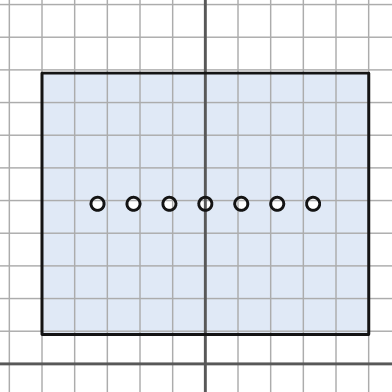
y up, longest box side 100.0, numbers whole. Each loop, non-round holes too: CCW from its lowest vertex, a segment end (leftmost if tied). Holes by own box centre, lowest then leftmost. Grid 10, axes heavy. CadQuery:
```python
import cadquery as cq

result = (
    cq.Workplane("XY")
    .moveTo(-50.0, 9.0)
    .lineTo(50.0, 9.0)
    .lineTo(50.0, 89.0)
    .lineTo(-50.0, 89.0)
    .close()
    .moveTo(-33.0, 49.0)
    .circle(2.0)
    .moveTo(-22.0, 49.0)
    .circle(2.0)
    .moveTo(-11.0, 49.0)
    .circle(2.0)
    .moveTo(0.0, 49.0)
    .circle(2.0)
    .moveTo(11.0, 49.0)
    .circle(2.0)
    .moveTo(22.0, 49.0)
    .circle(2.0)
    .moveTo(33.0, 49.0)
    .circle(2.0)
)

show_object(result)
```